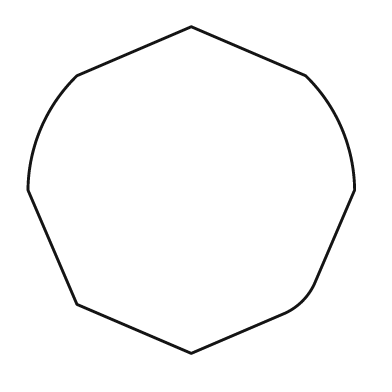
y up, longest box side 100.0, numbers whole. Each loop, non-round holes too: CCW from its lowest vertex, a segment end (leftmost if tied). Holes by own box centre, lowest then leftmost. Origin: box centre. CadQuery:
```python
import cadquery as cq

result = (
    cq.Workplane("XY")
    .moveTo(0.0, -50.0)
    .lineTo(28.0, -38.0)
    .threePointArc((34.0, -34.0), (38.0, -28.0))
    .lineTo(50.0, 0.0)
    .threePointArc((46.0, 19.0), (35.0, 35.0))
    .lineTo(0.0, 50.0)
    .lineTo(-35.0, 35.0)
    .threePointArc((-46.0, 19.0), (-50.0, 0.0))
    .lineTo(-35.0, -35.0)
    .close()
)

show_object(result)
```